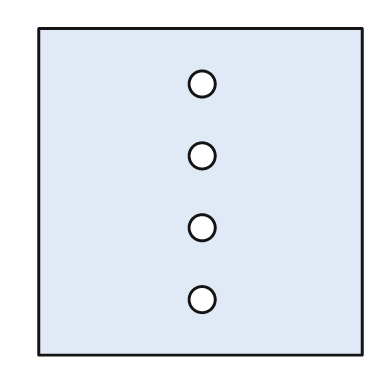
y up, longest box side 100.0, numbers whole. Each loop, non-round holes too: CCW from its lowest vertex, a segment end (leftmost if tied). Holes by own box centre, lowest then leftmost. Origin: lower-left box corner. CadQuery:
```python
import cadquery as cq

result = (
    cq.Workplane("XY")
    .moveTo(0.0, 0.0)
    .lineTo(99.0, 0.0)
    .lineTo(99.0, 100.0)
    .lineTo(0.0, 100.0)
    .close()
    .moveTo(50.0, 17.0)
    .circle(4.0)
    .moveTo(50.0, 39.0)
    .circle(4.0)
    .moveTo(50.0, 61.0)
    .circle(4.0)
    .moveTo(50.0, 83.0)
    .circle(4.0)
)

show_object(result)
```